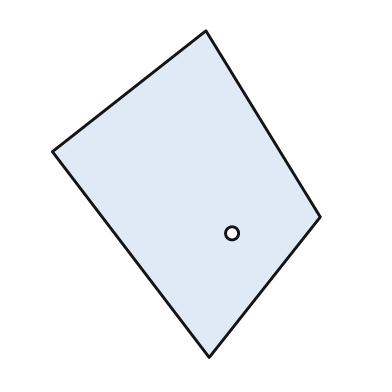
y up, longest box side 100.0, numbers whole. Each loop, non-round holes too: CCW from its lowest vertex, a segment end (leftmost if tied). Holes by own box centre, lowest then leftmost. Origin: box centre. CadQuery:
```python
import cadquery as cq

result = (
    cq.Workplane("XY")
    .moveTo(7.0, -50.0)
    .lineTo(41.0, -7.0)
    .lineTo(6.0, 50.0)
    .lineTo(-41.0, 13.0)
    .close()
    .moveTo(14.0, -12.0)
    .circle(2.0)
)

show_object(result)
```